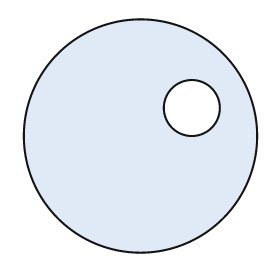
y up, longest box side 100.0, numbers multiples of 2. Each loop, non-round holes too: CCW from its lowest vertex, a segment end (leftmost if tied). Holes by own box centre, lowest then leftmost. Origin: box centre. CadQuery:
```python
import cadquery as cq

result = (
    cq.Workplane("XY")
    .moveTo(0.0, 0.0)
    .circle(50.0)
    .moveTo(22.0, 12.0)
    .circle(12.0)
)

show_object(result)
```